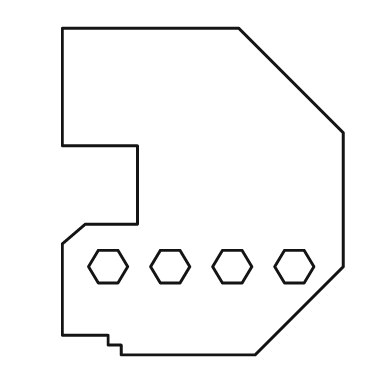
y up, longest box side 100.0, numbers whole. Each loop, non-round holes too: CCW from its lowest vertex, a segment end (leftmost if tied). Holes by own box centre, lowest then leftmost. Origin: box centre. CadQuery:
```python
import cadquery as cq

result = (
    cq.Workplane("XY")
    .moveTo(-25.0, -50.0)
    .lineTo(16.0, -50.0)
    .lineTo(43.0, -23.0)
    .lineTo(43.0, 18.0)
    .lineTo(11.0, 50.0)
    .lineTo(-43.0, 50.0)
    .lineTo(-43.0, 14.0)
    .lineTo(-20.0, 14.0)
    .lineTo(-20.0, -10.0)
    .lineTo(-36.0, -10.0)
    .lineTo(-43.0, -16.0)
    .lineTo(-43.0, -44.0)
    .lineTo(-29.0, -44.0)
    .lineTo(-29.0, -47.0)
    .lineTo(-25.0, -47.0)
    .close()
    .moveTo(-32.0, -28.0)
    .lineTo(-26.0, -28.0)
    .lineTo(-23.0, -23.0)
    .lineTo(-26.0, -18.0)
    .lineTo(-32.0, -18.0)
    .lineTo(-35.0, -23.0)
    .close()
    .moveTo(-13.0, -28.0)
    .lineTo(-7.0, -28.0)
    .lineTo(-4.0, -23.0)
    .lineTo(-7.0, -18.0)
    .lineTo(-13.0, -18.0)
    .lineTo(-16.0, -23.0)
    .close()
    .moveTo(6.0, -28.0)
    .lineTo(12.0, -28.0)
    .lineTo(15.0, -23.0)
    .lineTo(12.0, -18.0)
    .lineTo(6.0, -18.0)
    .lineTo(3.0, -23.0)
    .close()
    .moveTo(25.0, -28.0)
    .lineTo(31.0, -28.0)
    .lineTo(34.0, -23.0)
    .lineTo(31.0, -18.0)
    .lineTo(25.0, -18.0)
    .lineTo(22.0, -23.0)
    .close()
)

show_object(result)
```